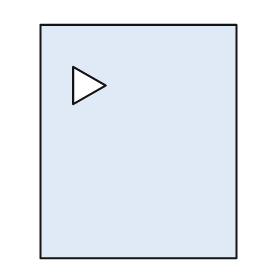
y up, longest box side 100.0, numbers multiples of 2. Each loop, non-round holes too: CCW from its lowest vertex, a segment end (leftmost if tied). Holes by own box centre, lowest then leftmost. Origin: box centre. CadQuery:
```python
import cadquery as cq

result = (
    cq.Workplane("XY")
    .moveTo(-42.0, -50.0)
    .lineTo(42.0, -50.0)
    .lineTo(42.0, 50.0)
    .lineTo(-42.0, 50.0)
    .close()
    .moveTo(-28.0, 16.0)
    .lineTo(-14.0, 24.0)
    .lineTo(-28.0, 32.0)
    .close()
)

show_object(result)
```